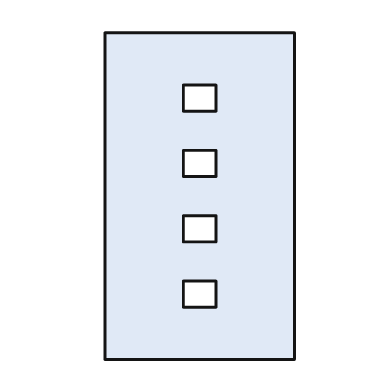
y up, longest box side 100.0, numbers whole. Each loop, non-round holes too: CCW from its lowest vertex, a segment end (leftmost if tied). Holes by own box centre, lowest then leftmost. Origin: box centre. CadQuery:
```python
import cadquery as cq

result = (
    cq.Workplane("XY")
    .moveTo(-29.0, -50.0)
    .lineTo(29.0, -50.0)
    .lineTo(29.0, 50.0)
    .lineTo(-29.0, 50.0)
    .close()
    .moveTo(-5.0, -34.0)
    .lineTo(5.0, -34.0)
    .lineTo(5.0, -26.0)
    .lineTo(-5.0, -26.0)
    .close()
    .moveTo(-5.0, -14.0)
    .lineTo(5.0, -14.0)
    .lineTo(5.0, -6.0)
    .lineTo(-5.0, -6.0)
    .close()
    .moveTo(-5.0, 6.0)
    .lineTo(5.0, 6.0)
    .lineTo(5.0, 14.0)
    .lineTo(-5.0, 14.0)
    .close()
    .moveTo(-5.0, 26.0)
    .lineTo(5.0, 26.0)
    .lineTo(5.0, 34.0)
    .lineTo(-5.0, 34.0)
    .close()
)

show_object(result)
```